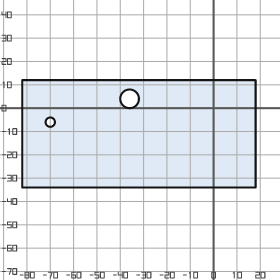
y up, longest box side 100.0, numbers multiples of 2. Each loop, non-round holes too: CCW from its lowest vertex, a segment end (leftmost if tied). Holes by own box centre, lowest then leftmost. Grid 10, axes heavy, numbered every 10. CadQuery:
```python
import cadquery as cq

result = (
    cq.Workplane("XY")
    .moveTo(-82.0, -34.0)
    .lineTo(18.0, -34.0)
    .lineTo(18.0, 12.0)
    .lineTo(-82.0, 12.0)
    .close()
    .moveTo(-70.0, -6.0)
    .circle(2.0)
    .moveTo(-36.0, 4.0)
    .circle(4.0)
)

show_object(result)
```